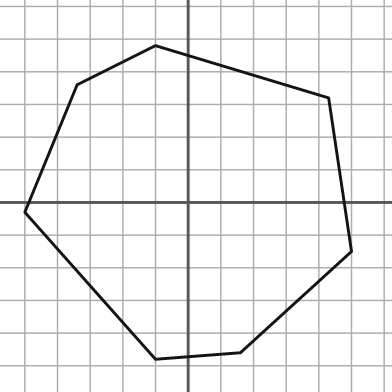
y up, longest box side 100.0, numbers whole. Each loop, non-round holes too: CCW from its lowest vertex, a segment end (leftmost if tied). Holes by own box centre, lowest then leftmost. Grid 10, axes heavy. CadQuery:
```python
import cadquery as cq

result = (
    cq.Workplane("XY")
    .moveTo(-10.0, -48.0)
    .lineTo(16.0, -46.0)
    .lineTo(50.0, -15.0)
    .lineTo(43.0, 32.0)
    .lineTo(-10.0, 48.0)
    .lineTo(-34.0, 36.0)
    .lineTo(-50.0, -3.0)
    .close()
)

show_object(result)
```